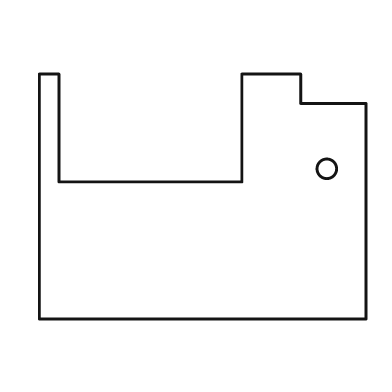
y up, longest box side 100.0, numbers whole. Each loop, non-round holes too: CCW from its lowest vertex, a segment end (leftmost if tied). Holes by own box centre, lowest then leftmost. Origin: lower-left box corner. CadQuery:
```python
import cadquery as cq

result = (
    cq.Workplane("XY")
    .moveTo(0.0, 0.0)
    .lineTo(100.0, 0.0)
    .lineTo(100.0, 66.0)
    .lineTo(80.0, 66.0)
    .lineTo(80.0, 75.0)
    .lineTo(62.0, 75.0)
    .lineTo(62.0, 42.0)
    .lineTo(6.0, 42.0)
    .lineTo(6.0, 75.0)
    .lineTo(0.0, 75.0)
    .close()
    .moveTo(88.0, 46.0)
    .circle(3.0)
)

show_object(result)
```